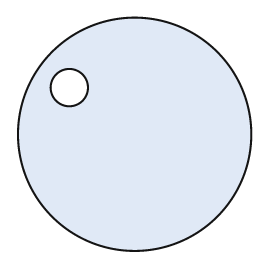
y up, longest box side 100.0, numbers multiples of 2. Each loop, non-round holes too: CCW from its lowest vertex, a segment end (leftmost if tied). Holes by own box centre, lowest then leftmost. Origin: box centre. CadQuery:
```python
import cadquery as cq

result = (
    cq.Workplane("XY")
    .moveTo(0.0, 0.0)
    .circle(50.0)
    .moveTo(-28.0, 20.0)
    .circle(8.0)
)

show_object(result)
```